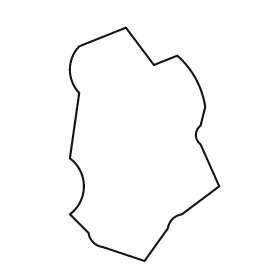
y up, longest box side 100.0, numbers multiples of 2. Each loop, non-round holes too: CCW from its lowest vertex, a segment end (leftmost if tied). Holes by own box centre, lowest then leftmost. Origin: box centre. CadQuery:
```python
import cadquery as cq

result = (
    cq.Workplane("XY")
    .moveTo(0.0, -50.0)
    .lineTo(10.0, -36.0)
    .threePointArc((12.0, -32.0), (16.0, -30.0))
    .lineTo(32.0, -18.0)
    .lineTo(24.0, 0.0)
    .threePointArc((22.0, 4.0), (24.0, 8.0))
    .lineTo(26.0, 16.0)
    .threePointArc((22.0, 28.0), (14.0, 38.0))
    .lineTo(4.0, 34.0)
    .lineTo(-8.0, 50.0)
    .lineTo(-28.0, 42.0)
    .threePointArc((-32.0, 32.0), (-28.0, 22.0))
    .lineTo(-32.0, -6.0)
    .threePointArc((-26.0, -18.0), (-32.0, -30.0))
    .lineTo(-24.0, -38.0)
    .threePointArc((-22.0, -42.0), (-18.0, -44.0))
    .close()
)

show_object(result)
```